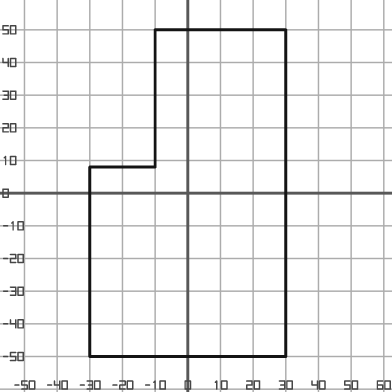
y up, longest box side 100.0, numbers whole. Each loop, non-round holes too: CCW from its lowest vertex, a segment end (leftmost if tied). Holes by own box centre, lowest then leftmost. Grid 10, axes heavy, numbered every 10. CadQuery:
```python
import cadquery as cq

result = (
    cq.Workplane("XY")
    .moveTo(-30.0, -50.0)
    .lineTo(30.0, -50.0)
    .lineTo(30.0, 50.0)
    .lineTo(-10.0, 50.0)
    .lineTo(-10.0, 8.0)
    .lineTo(-30.0, 8.0)
    .close()
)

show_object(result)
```